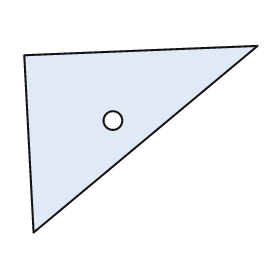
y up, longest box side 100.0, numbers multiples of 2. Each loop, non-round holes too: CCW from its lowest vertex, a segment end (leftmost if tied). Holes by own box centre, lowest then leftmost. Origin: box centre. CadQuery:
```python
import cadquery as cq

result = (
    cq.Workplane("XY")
    .moveTo(-46.0, -40.0)
    .lineTo(50.0, 40.0)
    .lineTo(-50.0, 36.0)
    .close()
    .moveTo(-12.0, 8.0)
    .circle(4.0)
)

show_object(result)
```